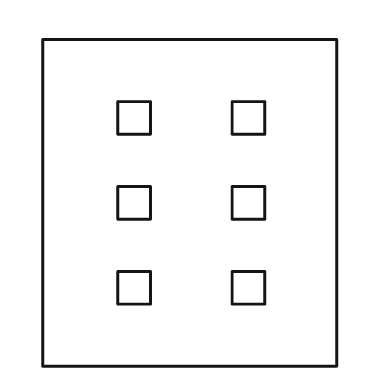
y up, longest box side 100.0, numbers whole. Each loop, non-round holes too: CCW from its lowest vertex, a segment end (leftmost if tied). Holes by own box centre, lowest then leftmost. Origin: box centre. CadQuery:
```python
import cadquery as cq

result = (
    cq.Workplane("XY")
    .moveTo(-45.0, -50.0)
    .lineTo(45.0, -50.0)
    .lineTo(45.0, 50.0)
    .lineTo(-45.0, 50.0)
    .close()
    .moveTo(-22.0, -31.0)
    .lineTo(-12.0, -31.0)
    .lineTo(-12.0, -21.0)
    .lineTo(-22.0, -21.0)
    .close()
    .moveTo(13.0, -31.0)
    .lineTo(23.0, -31.0)
    .lineTo(23.0, -21.0)
    .lineTo(13.0, -21.0)
    .close()
    .moveTo(-22.0, -5.0)
    .lineTo(-12.0, -5.0)
    .lineTo(-12.0, 5.0)
    .lineTo(-22.0, 5.0)
    .close()
    .moveTo(13.0, -5.0)
    .lineTo(23.0, -5.0)
    .lineTo(23.0, 5.0)
    .lineTo(13.0, 5.0)
    .close()
    .moveTo(-22.0, 21.0)
    .lineTo(-12.0, 21.0)
    .lineTo(-12.0, 31.0)
    .lineTo(-22.0, 31.0)
    .close()
    .moveTo(13.0, 21.0)
    .lineTo(23.0, 21.0)
    .lineTo(23.0, 31.0)
    .lineTo(13.0, 31.0)
    .close()
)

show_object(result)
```